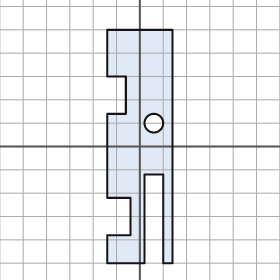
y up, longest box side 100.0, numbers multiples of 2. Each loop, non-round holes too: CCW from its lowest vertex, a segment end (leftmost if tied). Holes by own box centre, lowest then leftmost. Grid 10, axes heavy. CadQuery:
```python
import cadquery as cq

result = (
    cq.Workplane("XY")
    .moveTo(-14.0, -50.0)
    .lineTo(2.0, -50.0)
    .lineTo(2.0, -12.0)
    .lineTo(10.0, -12.0)
    .lineTo(10.0, -50.0)
    .lineTo(14.0, -50.0)
    .lineTo(14.0, 50.0)
    .lineTo(-14.0, 50.0)
    .lineTo(-14.0, 30.0)
    .lineTo(-6.0, 30.0)
    .lineTo(-6.0, 14.0)
    .lineTo(-14.0, 14.0)
    .lineTo(-14.0, -22.0)
    .lineTo(-4.0, -22.0)
    .lineTo(-4.0, -38.0)
    .lineTo(-14.0, -38.0)
    .close()
    .moveTo(6.0, 10.0)
    .circle(4.0)
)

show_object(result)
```